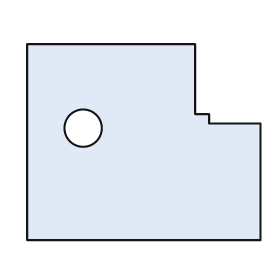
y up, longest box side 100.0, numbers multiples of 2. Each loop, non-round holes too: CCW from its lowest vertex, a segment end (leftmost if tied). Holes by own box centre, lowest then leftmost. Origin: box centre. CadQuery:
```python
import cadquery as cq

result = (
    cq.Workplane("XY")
    .moveTo(-50.0, -42.0)
    .lineTo(50.0, -42.0)
    .lineTo(50.0, 8.0)
    .lineTo(28.0, 8.0)
    .lineTo(28.0, 12.0)
    .lineTo(22.0, 12.0)
    .lineTo(22.0, 42.0)
    .lineTo(-50.0, 42.0)
    .close()
    .moveTo(-26.0, 6.0)
    .circle(8.0)
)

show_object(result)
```